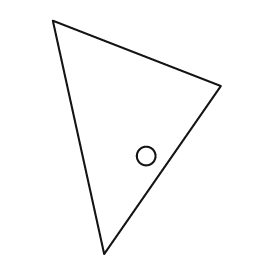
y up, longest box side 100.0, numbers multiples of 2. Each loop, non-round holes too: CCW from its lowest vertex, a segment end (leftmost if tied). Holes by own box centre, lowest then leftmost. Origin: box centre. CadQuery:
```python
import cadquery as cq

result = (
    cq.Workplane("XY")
    .moveTo(-14.0, -50.0)
    .lineTo(36.0, 22.0)
    .lineTo(-36.0, 50.0)
    .close()
    .moveTo(4.0, -8.0)
    .circle(4.0)
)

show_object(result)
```